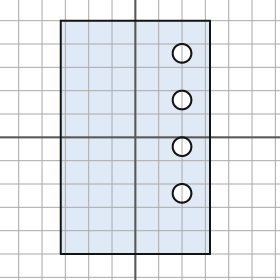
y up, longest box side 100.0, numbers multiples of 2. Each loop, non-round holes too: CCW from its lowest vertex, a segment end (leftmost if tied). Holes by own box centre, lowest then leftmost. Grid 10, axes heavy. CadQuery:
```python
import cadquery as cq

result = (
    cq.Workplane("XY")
    .moveTo(-32.0, -50.0)
    .lineTo(32.0, -50.0)
    .lineTo(32.0, 50.0)
    .lineTo(-32.0, 50.0)
    .close()
    .moveTo(20.0, -24.0)
    .circle(4.0)
    .moveTo(20.0, -4.0)
    .circle(4.0)
    .moveTo(20.0, 16.0)
    .circle(4.0)
    .moveTo(20.0, 36.0)
    .circle(4.0)
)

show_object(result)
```